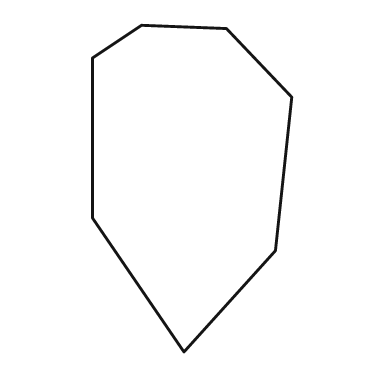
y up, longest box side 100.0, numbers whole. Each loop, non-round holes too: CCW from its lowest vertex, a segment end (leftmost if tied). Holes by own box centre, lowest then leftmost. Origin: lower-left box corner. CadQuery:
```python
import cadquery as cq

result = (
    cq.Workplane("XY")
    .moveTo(28.0, 0.0)
    .lineTo(56.0, 31.0)
    .lineTo(61.0, 78.0)
    .lineTo(41.0, 99.0)
    .lineTo(15.0, 100.0)
    .lineTo(0.0, 90.0)
    .lineTo(0.0, 41.0)
    .close()
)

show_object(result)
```